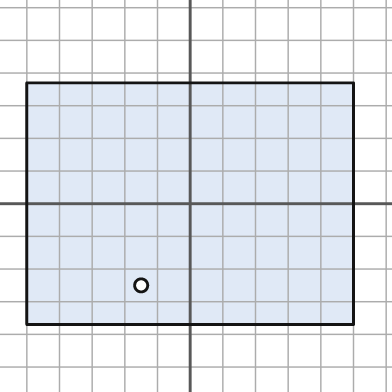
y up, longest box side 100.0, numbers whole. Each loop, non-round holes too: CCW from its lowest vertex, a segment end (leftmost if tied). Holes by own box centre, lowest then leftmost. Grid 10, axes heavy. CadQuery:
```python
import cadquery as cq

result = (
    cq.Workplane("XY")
    .moveTo(-50.0, -37.0)
    .lineTo(50.0, -37.0)
    .lineTo(50.0, 37.0)
    .lineTo(-50.0, 37.0)
    .close()
    .moveTo(-15.0, -25.0)
    .circle(2.0)
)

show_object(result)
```